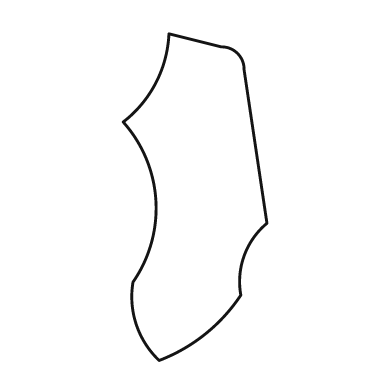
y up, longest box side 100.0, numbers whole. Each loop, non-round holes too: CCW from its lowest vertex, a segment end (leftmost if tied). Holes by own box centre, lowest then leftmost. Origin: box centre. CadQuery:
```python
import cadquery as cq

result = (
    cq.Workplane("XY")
    .moveTo(-11.0, -50.0)
    .threePointArc((3.0, -42.0), (14.0, -30.0))
    .threePointArc((15.0, -18.0), (22.0, -8.0))
    .lineTo(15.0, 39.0)
    .threePointArc((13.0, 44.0), (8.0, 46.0))
    .lineTo(-8.0, 50.0)
    .threePointArc((-12.0, 35.0), (-22.0, 23.0))
    .threePointArc((-12.0, -1.0), (-19.0, -26.0))
    .threePointArc((-18.0, -39.0), (-11.0, -50.0))
    .close()
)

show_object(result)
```